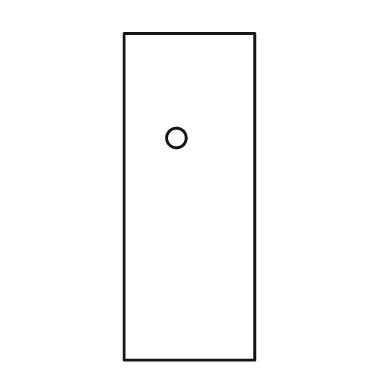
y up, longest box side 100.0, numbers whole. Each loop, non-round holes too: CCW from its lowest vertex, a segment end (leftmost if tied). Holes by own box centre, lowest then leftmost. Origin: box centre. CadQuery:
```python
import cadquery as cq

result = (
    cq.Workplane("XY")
    .moveTo(-20.0, -50.0)
    .lineTo(20.0, -50.0)
    .lineTo(20.0, 50.0)
    .lineTo(-20.0, 50.0)
    .close()
    .moveTo(-4.0, 18.0)
    .circle(3.0)
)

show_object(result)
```